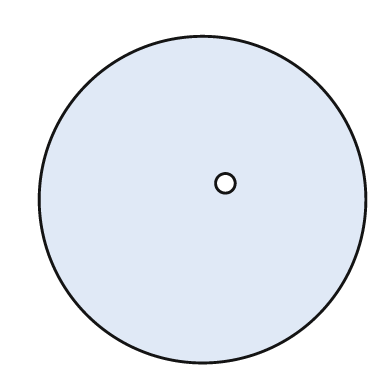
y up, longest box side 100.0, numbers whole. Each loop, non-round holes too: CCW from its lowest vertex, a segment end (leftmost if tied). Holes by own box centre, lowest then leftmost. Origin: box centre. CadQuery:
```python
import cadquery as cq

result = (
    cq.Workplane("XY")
    .moveTo(0.0, 0.0)
    .circle(50.0)
    .moveTo(7.0, 5.0)
    .circle(3.0)
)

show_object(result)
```